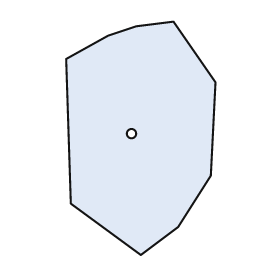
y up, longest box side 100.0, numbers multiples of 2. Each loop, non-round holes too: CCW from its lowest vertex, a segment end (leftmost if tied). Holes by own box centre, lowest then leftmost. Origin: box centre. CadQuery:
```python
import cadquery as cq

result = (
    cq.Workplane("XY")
    .moveTo(0.0, -50.0)
    .lineTo(16.0, -38.0)
    .lineTo(30.0, -16.0)
    .lineTo(32.0, 24.0)
    .lineTo(14.0, 50.0)
    .lineTo(-2.0, 48.0)
    .lineTo(-14.0, 44.0)
    .lineTo(-32.0, 34.0)
    .lineTo(-30.0, -28.0)
    .close()
    .moveTo(-4.0, 2.0)
    .circle(2.0)
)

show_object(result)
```